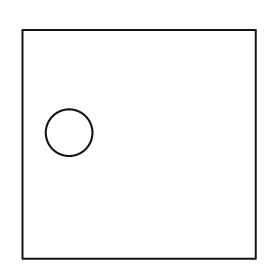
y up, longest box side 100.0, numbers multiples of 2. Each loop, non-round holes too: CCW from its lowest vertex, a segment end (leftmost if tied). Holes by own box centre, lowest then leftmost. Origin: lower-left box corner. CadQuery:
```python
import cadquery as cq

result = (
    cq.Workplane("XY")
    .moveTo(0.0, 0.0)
    .lineTo(100.0, 0.0)
    .lineTo(100.0, 98.0)
    .lineTo(0.0, 98.0)
    .close()
    .moveTo(20.0, 54.0)
    .circle(10.0)
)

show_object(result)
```